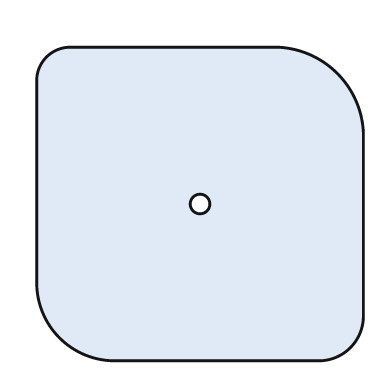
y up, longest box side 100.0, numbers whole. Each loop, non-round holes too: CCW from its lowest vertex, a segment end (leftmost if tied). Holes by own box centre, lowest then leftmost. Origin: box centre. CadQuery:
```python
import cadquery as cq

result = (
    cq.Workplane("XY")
    .moveTo(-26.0, -48.0)
    .lineTo(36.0, -48.0)
    .threePointArc((46.0, -44.0), (50.0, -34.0))
    .lineTo(50.0, 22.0)
    .threePointArc((42.0, 40.0), (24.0, 48.0))
    .lineTo(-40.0, 48.0)
    .threePointArc((-47.0, 45.0), (-50.0, 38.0))
    .lineTo(-50.0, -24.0)
    .threePointArc((-43.0, -41.0), (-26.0, -48.0))
    .close()
    .moveTo(0.0, 0.0)
    .circle(3.0)
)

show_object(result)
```